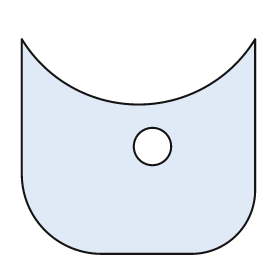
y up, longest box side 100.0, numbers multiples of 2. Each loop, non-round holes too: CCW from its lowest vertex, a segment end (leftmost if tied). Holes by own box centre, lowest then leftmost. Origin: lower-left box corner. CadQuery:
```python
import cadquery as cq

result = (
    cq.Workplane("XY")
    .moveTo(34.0, 0.0)
    .lineTo(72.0, 0.0)
    .threePointArc((92.0, 8.0), (100.0, 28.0))
    .lineTo(100.0, 92.0)
    .threePointArc((50.0, 64.0), (0.0, 92.0))
    .lineTo(0.0, 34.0)
    .threePointArc((10.0, 10.0), (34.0, 0.0))
    .close()
    .moveTo(56.0, 46.0)
    .circle(8.0)
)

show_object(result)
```